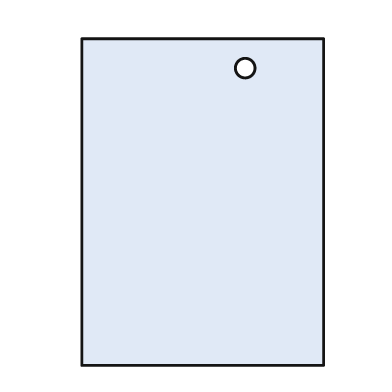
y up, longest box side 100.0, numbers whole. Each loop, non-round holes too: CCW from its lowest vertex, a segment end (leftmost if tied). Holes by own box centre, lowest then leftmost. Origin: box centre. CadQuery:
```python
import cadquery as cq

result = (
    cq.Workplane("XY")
    .moveTo(-37.0, -50.0)
    .lineTo(37.0, -50.0)
    .lineTo(37.0, 50.0)
    .lineTo(-37.0, 50.0)
    .close()
    .moveTo(13.0, 41.0)
    .circle(3.0)
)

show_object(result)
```